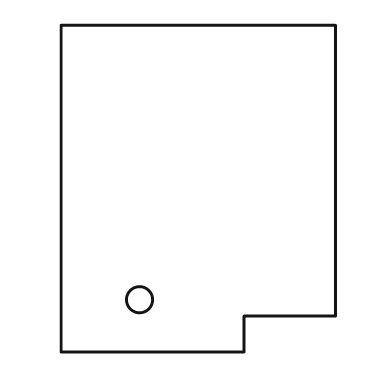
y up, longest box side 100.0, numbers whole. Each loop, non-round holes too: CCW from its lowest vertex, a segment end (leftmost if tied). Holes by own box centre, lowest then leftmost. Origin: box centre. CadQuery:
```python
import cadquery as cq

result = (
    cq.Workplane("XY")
    .moveTo(-42.0, -50.0)
    .lineTo(14.0, -50.0)
    .lineTo(14.0, -39.0)
    .lineTo(42.0, -39.0)
    .lineTo(42.0, 50.0)
    .lineTo(-42.0, 50.0)
    .close()
    .moveTo(-18.0, -34.0)
    .circle(4.0)
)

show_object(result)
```